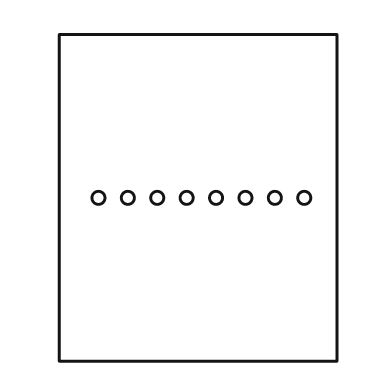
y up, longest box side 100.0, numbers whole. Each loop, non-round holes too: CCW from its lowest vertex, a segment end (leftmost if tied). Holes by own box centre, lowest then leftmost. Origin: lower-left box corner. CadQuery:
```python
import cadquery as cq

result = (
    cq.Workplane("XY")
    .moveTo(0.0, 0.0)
    .lineTo(85.0, 0.0)
    .lineTo(85.0, 100.0)
    .lineTo(0.0, 100.0)
    .close()
    .moveTo(12.0, 50.0)
    .circle(2.0)
    .moveTo(21.0, 50.0)
    .circle(2.0)
    .moveTo(30.0, 50.0)
    .circle(2.0)
    .moveTo(39.0, 50.0)
    .circle(2.0)
    .moveTo(48.0, 50.0)
    .circle(2.0)
    .moveTo(57.0, 50.0)
    .circle(2.0)
    .moveTo(66.0, 50.0)
    .circle(2.0)
    .moveTo(75.0, 50.0)
    .circle(2.0)
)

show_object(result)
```